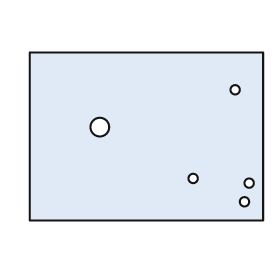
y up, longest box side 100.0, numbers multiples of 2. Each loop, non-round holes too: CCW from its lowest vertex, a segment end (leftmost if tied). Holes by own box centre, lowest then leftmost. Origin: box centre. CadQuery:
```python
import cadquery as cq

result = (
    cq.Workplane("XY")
    .moveTo(-50.0, -36.0)
    .lineTo(50.0, -36.0)
    .lineTo(50.0, 36.0)
    .lineTo(-50.0, 36.0)
    .close()
    .moveTo(42.0, -28.0)
    .circle(2.0)
    .moveTo(44.0, -20.0)
    .circle(2.0)
    .moveTo(20.0, -18.0)
    .circle(2.0)
    .moveTo(-20.0, 4.0)
    .circle(4.0)
    .moveTo(38.0, 20.0)
    .circle(2.0)
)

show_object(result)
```